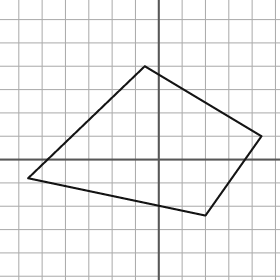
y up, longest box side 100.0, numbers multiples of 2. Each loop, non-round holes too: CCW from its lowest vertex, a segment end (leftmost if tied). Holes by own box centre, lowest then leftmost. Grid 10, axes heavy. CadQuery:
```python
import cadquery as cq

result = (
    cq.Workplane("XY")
    .moveTo(20.0, -24.0)
    .lineTo(44.0, 10.0)
    .lineTo(-6.0, 40.0)
    .lineTo(-56.0, -8.0)
    .close()
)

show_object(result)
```